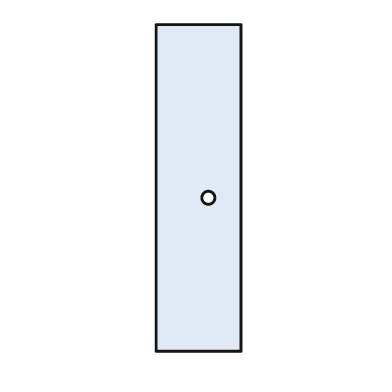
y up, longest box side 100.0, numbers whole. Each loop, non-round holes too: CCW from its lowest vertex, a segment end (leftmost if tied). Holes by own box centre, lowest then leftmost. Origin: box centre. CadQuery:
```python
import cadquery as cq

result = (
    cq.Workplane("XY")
    .moveTo(-13.0, -50.0)
    .lineTo(13.0, -50.0)
    .lineTo(13.0, 50.0)
    .lineTo(-13.0, 50.0)
    .close()
    .moveTo(3.0, -3.0)
    .circle(2.0)
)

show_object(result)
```